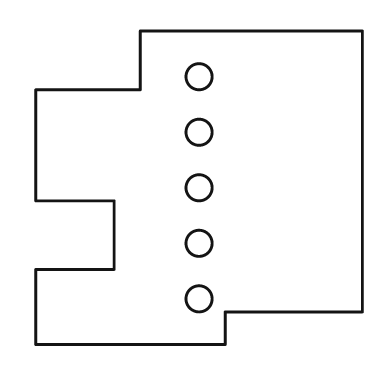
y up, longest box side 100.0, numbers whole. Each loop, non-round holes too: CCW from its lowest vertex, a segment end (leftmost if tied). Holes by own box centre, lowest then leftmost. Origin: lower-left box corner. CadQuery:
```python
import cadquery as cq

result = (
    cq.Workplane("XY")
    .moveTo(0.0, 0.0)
    .lineTo(58.0, 0.0)
    .lineTo(58.0, 10.0)
    .lineTo(100.0, 10.0)
    .lineTo(100.0, 96.0)
    .lineTo(32.0, 96.0)
    .lineTo(32.0, 78.0)
    .lineTo(0.0, 78.0)
    .lineTo(0.0, 44.0)
    .lineTo(24.0, 44.0)
    .lineTo(24.0, 23.0)
    .lineTo(0.0, 23.0)
    .close()
    .moveTo(50.0, 14.0)
    .circle(4.0)
    .moveTo(50.0, 31.0)
    .circle(4.0)
    .moveTo(50.0, 48.0)
    .circle(4.0)
    .moveTo(50.0, 65.0)
    .circle(4.0)
    .moveTo(50.0, 82.0)
    .circle(4.0)
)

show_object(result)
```